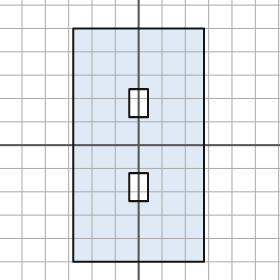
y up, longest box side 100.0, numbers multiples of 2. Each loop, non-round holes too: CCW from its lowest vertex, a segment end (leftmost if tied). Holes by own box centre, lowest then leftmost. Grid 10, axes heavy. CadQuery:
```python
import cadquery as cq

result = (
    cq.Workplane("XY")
    .moveTo(-28.0, -50.0)
    .lineTo(28.0, -50.0)
    .lineTo(28.0, 50.0)
    .lineTo(-28.0, 50.0)
    .close()
    .moveTo(-4.0, -24.0)
    .lineTo(4.0, -24.0)
    .lineTo(4.0, -12.0)
    .lineTo(-4.0, -12.0)
    .close()
    .moveTo(-4.0, 12.0)
    .lineTo(4.0, 12.0)
    .lineTo(4.0, 24.0)
    .lineTo(-4.0, 24.0)
    .close()
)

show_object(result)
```